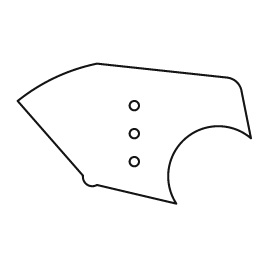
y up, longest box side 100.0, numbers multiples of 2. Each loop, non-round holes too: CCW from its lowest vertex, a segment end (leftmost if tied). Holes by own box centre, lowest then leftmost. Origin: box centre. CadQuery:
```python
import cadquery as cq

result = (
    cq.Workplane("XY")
    .moveTo(18.0, -30.0)
    .threePointArc((22.0, -2.0), (50.0, -2.0))
    .lineTo(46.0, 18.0)
    .threePointArc((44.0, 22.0), (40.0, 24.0))
    .lineTo(-16.0, 30.0)
    .threePointArc((-34.0, 24.0), (-50.0, 14.0))
    .lineTo(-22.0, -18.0)
    .threePointArc((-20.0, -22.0), (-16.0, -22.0))
    .close()
    .moveTo(0.0, -12.0)
    .circle(2.0)
    .moveTo(0.0, 0.0)
    .circle(2.0)
    .moveTo(0.0, 12.0)
    .circle(2.0)
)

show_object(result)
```